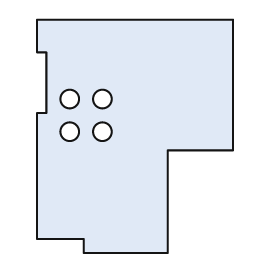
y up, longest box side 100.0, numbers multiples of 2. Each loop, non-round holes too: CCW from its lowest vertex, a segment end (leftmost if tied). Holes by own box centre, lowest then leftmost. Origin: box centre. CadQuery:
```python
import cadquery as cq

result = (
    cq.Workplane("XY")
    .moveTo(-22.0, -50.0)
    .lineTo(14.0, -50.0)
    .lineTo(14.0, -6.0)
    .lineTo(42.0, -6.0)
    .lineTo(42.0, 50.0)
    .lineTo(-42.0, 50.0)
    .lineTo(-42.0, 36.0)
    .lineTo(-38.0, 36.0)
    .lineTo(-38.0, 10.0)
    .lineTo(-42.0, 10.0)
    .lineTo(-42.0, -44.0)
    .lineTo(-22.0, -44.0)
    .close()
    .moveTo(-28.0, 2.0)
    .circle(4.0)
    .moveTo(-14.0, 2.0)
    .circle(4.0)
    .moveTo(-28.0, 16.0)
    .circle(4.0)
    .moveTo(-14.0, 16.0)
    .circle(4.0)
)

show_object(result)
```